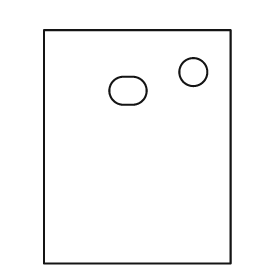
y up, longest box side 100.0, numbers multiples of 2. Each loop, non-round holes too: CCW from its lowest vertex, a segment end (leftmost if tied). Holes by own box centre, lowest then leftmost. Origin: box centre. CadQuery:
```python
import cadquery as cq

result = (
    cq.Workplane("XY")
    .moveTo(-40.0, -50.0)
    .lineTo(40.0, -50.0)
    .lineTo(40.0, 50.0)
    .lineTo(-40.0, 50.0)
    .close()
    .moveTo(-6.0, 18.0)
    .lineTo(-2.0, 18.0)
    .threePointArc((4.0, 24.0), (-2.0, 30.0))
    .lineTo(-6.0, 30.0)
    .threePointArc((-12.0, 24.0), (-6.0, 18.0))
    .close()
    .moveTo(24.0, 32.0)
    .circle(6.0)
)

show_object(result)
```